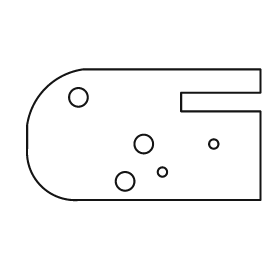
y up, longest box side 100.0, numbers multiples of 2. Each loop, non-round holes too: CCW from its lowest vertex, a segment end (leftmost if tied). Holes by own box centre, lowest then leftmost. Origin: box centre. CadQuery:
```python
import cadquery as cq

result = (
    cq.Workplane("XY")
    .moveTo(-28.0, -28.0)
    .lineTo(50.0, -28.0)
    .lineTo(50.0, 10.0)
    .lineTo(16.0, 10.0)
    .lineTo(16.0, 18.0)
    .lineTo(50.0, 18.0)
    .lineTo(50.0, 28.0)
    .lineTo(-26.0, 28.0)
    .threePointArc((-42.0, 20.0), (-50.0, 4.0))
    .lineTo(-50.0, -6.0)
    .threePointArc((-44.0, -22.0), (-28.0, -28.0))
    .close()
    .moveTo(-8.0, -20.0)
    .circle(4.0)
    .moveTo(8.0, -16.0)
    .circle(2.0)
    .moveTo(0.0, -4.0)
    .circle(4.0)
    .moveTo(30.0, -4.0)
    .circle(2.0)
    .moveTo(-28.0, 16.0)
    .circle(4.0)
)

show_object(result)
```